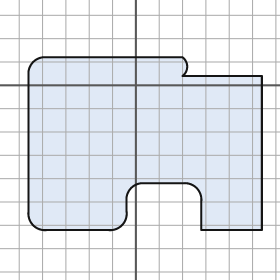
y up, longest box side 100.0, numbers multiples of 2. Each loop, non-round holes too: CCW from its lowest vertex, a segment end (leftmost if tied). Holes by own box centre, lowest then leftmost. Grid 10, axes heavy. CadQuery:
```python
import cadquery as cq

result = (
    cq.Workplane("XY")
    .moveTo(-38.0, -62.0)
    .lineTo(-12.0, -62.0)
    .threePointArc((-6.0, -60.0), (-4.0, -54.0))
    .lineTo(-4.0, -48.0)
    .threePointArc((-2.0, -44.0), (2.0, -42.0))
    .lineTo(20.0, -42.0)
    .threePointArc((26.0, -44.0), (28.0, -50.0))
    .lineTo(28.0, -62.0)
    .lineTo(54.0, -62.0)
    .lineTo(54.0, 4.0)
    .lineTo(20.0, 4.0)
    .threePointArc((22.0, 8.0), (20.0, 12.0))
    .lineTo(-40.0, 12.0)
    .threePointArc((-44.0, 10.0), (-46.0, 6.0))
    .lineTo(-46.0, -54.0)
    .threePointArc((-44.0, -60.0), (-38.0, -62.0))
    .close()
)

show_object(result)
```